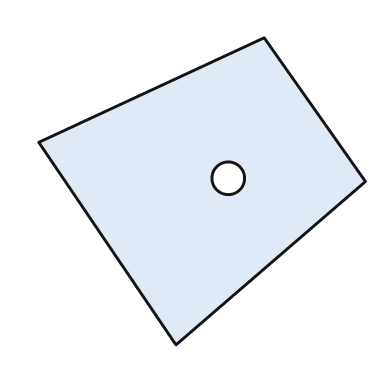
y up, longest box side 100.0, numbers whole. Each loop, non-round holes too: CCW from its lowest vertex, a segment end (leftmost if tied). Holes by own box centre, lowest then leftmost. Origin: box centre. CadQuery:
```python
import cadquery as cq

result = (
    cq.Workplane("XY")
    .moveTo(-8.0, -47.0)
    .lineTo(50.0, 3.0)
    .lineTo(19.0, 47.0)
    .lineTo(-50.0, 15.0)
    .close()
    .moveTo(8.0, 4.0)
    .circle(5.0)
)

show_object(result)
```